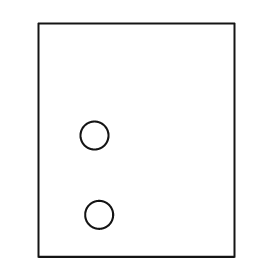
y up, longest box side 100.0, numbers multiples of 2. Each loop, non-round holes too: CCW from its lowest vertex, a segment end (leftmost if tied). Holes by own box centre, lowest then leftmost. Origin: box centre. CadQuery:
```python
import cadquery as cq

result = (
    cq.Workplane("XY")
    .moveTo(-42.0, -50.0)
    .lineTo(42.0, -50.0)
    .lineTo(42.0, 50.0)
    .lineTo(-42.0, 50.0)
    .close()
    .moveTo(-16.0, -32.0)
    .circle(6.0)
    .moveTo(-18.0, 2.0)
    .circle(6.0)
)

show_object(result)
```